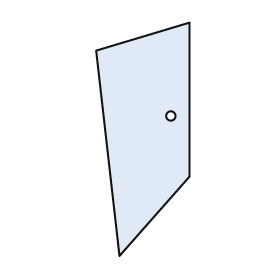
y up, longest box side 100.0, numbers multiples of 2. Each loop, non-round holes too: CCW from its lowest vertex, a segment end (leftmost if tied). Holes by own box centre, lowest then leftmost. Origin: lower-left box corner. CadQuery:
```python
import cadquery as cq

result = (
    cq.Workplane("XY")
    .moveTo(10.0, 0.0)
    .lineTo(40.0, 34.0)
    .lineTo(40.0, 100.0)
    .lineTo(0.0, 88.0)
    .close()
    .moveTo(32.0, 60.0)
    .circle(2.0)
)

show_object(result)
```